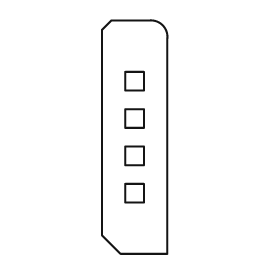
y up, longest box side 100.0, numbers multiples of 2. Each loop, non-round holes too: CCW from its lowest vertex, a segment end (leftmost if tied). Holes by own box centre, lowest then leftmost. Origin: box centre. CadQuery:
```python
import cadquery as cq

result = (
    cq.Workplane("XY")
    .moveTo(-6.0, -50.0)
    .lineTo(14.0, -50.0)
    .lineTo(14.0, 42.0)
    .threePointArc((12.0, 48.0), (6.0, 50.0))
    .lineTo(-10.0, 50.0)
    .lineTo(-14.0, 46.0)
    .lineTo(-14.0, -42.0)
    .close()
    .moveTo(-4.0, -28.0)
    .lineTo(4.0, -28.0)
    .lineTo(4.0, -20.0)
    .lineTo(-4.0, -20.0)
    .close()
    .moveTo(-4.0, -12.0)
    .lineTo(4.0, -12.0)
    .lineTo(4.0, -4.0)
    .lineTo(-4.0, -4.0)
    .close()
    .moveTo(-4.0, 4.0)
    .lineTo(4.0, 4.0)
    .lineTo(4.0, 12.0)
    .lineTo(-4.0, 12.0)
    .close()
    .moveTo(-4.0, 20.0)
    .lineTo(4.0, 20.0)
    .lineTo(4.0, 28.0)
    .lineTo(-4.0, 28.0)
    .close()
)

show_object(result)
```